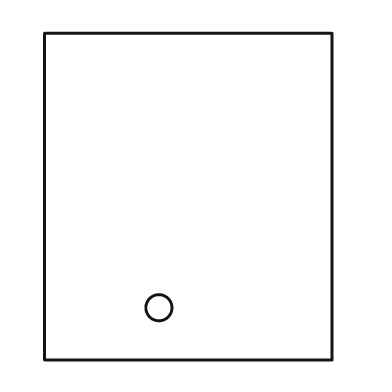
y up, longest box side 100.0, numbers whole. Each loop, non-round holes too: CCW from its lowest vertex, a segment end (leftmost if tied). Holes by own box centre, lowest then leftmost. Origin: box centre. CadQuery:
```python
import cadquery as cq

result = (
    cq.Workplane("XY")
    .moveTo(-44.0, -50.0)
    .lineTo(44.0, -50.0)
    .lineTo(44.0, 50.0)
    .lineTo(-44.0, 50.0)
    .close()
    .moveTo(-9.0, -34.0)
    .circle(4.0)
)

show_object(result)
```